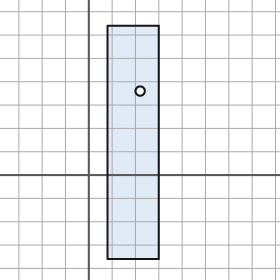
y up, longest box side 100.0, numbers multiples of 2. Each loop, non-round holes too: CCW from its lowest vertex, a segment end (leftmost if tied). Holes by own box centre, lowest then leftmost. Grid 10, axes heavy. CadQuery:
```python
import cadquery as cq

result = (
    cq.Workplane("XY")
    .moveTo(8.0, -36.0)
    .lineTo(30.0, -36.0)
    .lineTo(30.0, 64.0)
    .lineTo(8.0, 64.0)
    .close()
    .moveTo(22.0, 36.0)
    .circle(2.0)
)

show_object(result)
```